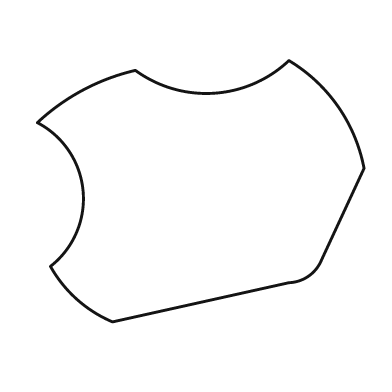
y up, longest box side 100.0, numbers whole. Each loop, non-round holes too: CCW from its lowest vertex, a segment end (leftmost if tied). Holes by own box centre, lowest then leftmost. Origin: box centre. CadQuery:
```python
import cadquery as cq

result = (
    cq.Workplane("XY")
    .moveTo(-27.0, -40.0)
    .lineTo(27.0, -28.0)
    .threePointArc((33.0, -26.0), (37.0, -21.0))
    .lineTo(50.0, 7.0)
    .threePointArc((42.0, 26.0), (27.0, 40.0))
    .threePointArc((4.0, 30.0), (-20.0, 37.0))
    .threePointArc((-36.0, 31.0), (-50.0, 21.0))
    .threePointArc((-36.0, 0.0), (-46.0, -23.0))
    .threePointArc((-38.0, -33.0), (-27.0, -40.0))
    .close()
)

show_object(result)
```